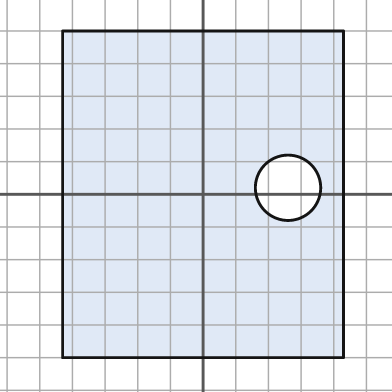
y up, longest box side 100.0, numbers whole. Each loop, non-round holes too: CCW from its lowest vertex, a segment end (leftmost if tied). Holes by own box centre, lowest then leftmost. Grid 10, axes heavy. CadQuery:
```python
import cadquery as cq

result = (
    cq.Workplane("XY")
    .moveTo(-43.0, -50.0)
    .lineTo(43.0, -50.0)
    .lineTo(43.0, 50.0)
    .lineTo(-43.0, 50.0)
    .close()
    .moveTo(26.0, 2.0)
    .circle(10.0)
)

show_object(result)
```